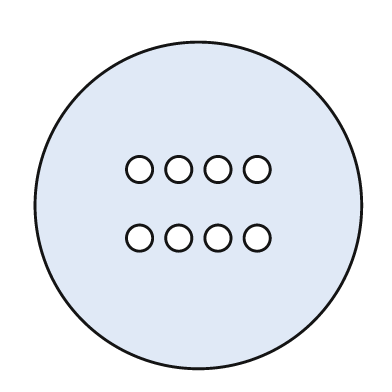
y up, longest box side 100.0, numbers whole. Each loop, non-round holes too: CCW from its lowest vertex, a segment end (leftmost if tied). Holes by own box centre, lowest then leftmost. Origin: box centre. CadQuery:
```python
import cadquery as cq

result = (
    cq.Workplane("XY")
    .moveTo(0.0, 0.0)
    .circle(50.0)
    .moveTo(-18.0, -10.0)
    .circle(4.0)
    .moveTo(-6.0, -10.0)
    .circle(4.0)
    .moveTo(6.0, -10.0)
    .circle(4.0)
    .moveTo(18.0, -10.0)
    .circle(4.0)
    .moveTo(-18.0, 11.0)
    .circle(4.0)
    .moveTo(-6.0, 11.0)
    .circle(4.0)
    .moveTo(6.0, 11.0)
    .circle(4.0)
    .moveTo(18.0, 11.0)
    .circle(4.0)
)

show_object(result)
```